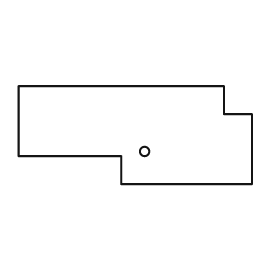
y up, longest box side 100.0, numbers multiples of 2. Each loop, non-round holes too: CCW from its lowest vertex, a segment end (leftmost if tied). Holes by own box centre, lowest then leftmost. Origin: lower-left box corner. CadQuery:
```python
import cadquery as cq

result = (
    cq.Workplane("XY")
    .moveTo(44.0, 0.0)
    .lineTo(100.0, 0.0)
    .lineTo(100.0, 30.0)
    .lineTo(88.0, 30.0)
    .lineTo(88.0, 42.0)
    .lineTo(0.0, 42.0)
    .lineTo(0.0, 12.0)
    .lineTo(44.0, 12.0)
    .close()
    .moveTo(54.0, 14.0)
    .circle(2.0)
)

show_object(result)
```